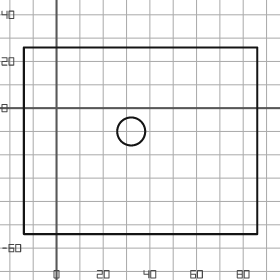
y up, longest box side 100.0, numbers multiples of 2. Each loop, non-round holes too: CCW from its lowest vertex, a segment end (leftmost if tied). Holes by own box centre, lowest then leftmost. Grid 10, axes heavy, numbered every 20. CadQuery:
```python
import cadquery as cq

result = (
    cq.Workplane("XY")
    .moveTo(-14.0, -54.0)
    .lineTo(86.0, -54.0)
    .lineTo(86.0, 26.0)
    .lineTo(-14.0, 26.0)
    .close()
    .moveTo(32.0, -10.0)
    .circle(6.0)
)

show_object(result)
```